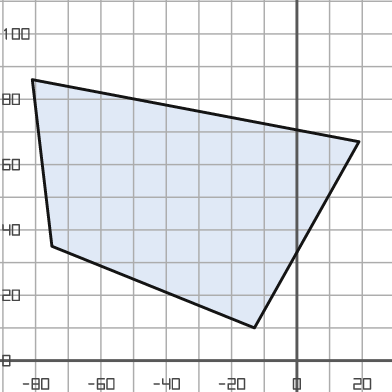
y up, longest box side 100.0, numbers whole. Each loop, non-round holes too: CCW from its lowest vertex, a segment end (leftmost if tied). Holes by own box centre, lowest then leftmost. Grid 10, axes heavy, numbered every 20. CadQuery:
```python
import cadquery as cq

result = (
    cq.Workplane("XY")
    .moveTo(-13.0, 10.0)
    .lineTo(19.0, 67.0)
    .lineTo(-81.0, 86.0)
    .lineTo(-75.0, 35.0)
    .close()
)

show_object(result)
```